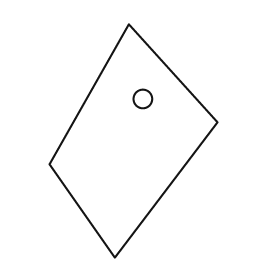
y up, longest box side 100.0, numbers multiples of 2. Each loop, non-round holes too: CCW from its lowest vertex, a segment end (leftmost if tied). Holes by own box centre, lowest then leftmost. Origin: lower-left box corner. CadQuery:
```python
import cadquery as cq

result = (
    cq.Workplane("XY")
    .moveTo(28.0, 0.0)
    .lineTo(72.0, 58.0)
    .lineTo(34.0, 100.0)
    .lineTo(0.0, 40.0)
    .close()
    .moveTo(40.0, 68.0)
    .circle(4.0)
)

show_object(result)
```